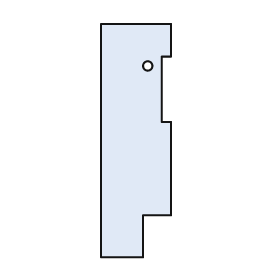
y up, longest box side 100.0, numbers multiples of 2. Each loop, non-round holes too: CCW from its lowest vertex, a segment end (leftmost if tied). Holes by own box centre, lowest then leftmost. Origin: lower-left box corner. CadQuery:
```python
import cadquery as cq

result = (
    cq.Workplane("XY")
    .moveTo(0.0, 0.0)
    .lineTo(18.0, 0.0)
    .lineTo(18.0, 18.0)
    .lineTo(30.0, 18.0)
    .lineTo(30.0, 58.0)
    .lineTo(26.0, 58.0)
    .lineTo(26.0, 86.0)
    .lineTo(30.0, 86.0)
    .lineTo(30.0, 100.0)
    .lineTo(0.0, 100.0)
    .close()
    .moveTo(20.0, 82.0)
    .circle(2.0)
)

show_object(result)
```